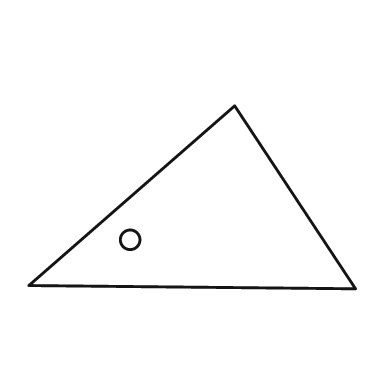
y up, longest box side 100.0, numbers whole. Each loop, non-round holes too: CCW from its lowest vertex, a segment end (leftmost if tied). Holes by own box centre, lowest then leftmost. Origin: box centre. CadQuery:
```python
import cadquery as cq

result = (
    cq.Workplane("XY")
    .moveTo(50.0, -28.0)
    .lineTo(13.0, 28.0)
    .lineTo(-50.0, -27.0)
    .close()
    .moveTo(-19.0, -13.0)
    .circle(3.0)
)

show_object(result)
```